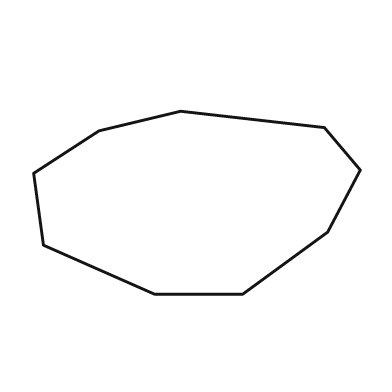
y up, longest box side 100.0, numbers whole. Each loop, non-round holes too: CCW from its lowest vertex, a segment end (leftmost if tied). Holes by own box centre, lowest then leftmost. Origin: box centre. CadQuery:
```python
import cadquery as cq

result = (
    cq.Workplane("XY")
    .moveTo(-13.0, -28.0)
    .lineTo(14.0, -28.0)
    .lineTo(40.0, -9.0)
    .lineTo(50.0, 10.0)
    .lineTo(39.0, 23.0)
    .lineTo(-5.0, 28.0)
    .lineTo(-30.0, 22.0)
    .lineTo(-50.0, 9.0)
    .lineTo(-47.0, -13.0)
    .close()
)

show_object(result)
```